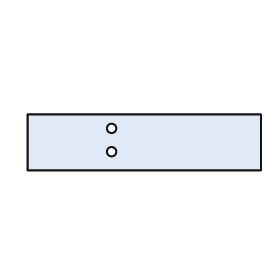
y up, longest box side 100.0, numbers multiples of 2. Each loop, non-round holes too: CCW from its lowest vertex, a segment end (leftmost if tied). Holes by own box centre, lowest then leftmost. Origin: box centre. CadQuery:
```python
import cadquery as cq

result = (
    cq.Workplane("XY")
    .moveTo(-50.0, -12.0)
    .lineTo(50.0, -12.0)
    .lineTo(50.0, 12.0)
    .lineTo(-50.0, 12.0)
    .close()
    .moveTo(-14.0, -4.0)
    .circle(2.0)
    .moveTo(-14.0, 6.0)
    .circle(2.0)
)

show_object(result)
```